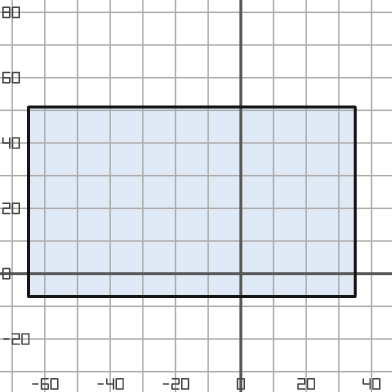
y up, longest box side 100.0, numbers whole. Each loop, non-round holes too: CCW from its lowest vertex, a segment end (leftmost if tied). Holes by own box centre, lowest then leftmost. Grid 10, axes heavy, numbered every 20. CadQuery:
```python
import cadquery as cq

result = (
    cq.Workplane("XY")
    .moveTo(-65.0, -7.0)
    .lineTo(35.0, -7.0)
    .lineTo(35.0, 51.0)
    .lineTo(-65.0, 51.0)
    .close()
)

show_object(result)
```